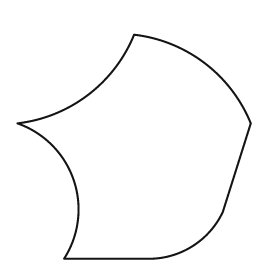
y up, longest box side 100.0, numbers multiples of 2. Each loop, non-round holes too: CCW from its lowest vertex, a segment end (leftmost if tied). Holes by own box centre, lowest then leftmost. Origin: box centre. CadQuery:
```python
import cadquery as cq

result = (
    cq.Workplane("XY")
    .moveTo(-30.0, -48.0)
    .lineTo(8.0, -48.0)
    .threePointArc((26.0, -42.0), (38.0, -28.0))
    .lineTo(50.0, 10.0)
    .threePointArc((30.0, 36.0), (0.0, 48.0))
    .threePointArc((-20.0, 22.0), (-50.0, 10.0))
    .threePointArc((-26.0, -14.0), (-30.0, -48.0))
    .close()
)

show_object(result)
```